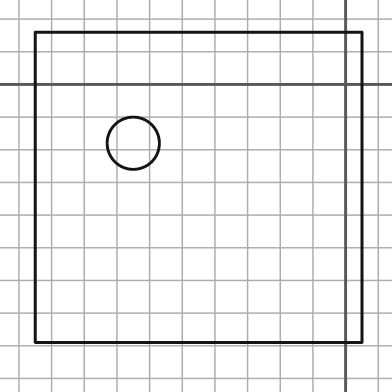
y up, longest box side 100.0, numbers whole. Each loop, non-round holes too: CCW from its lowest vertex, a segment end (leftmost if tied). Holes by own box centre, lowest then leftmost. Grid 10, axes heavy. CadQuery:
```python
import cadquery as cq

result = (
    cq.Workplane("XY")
    .moveTo(-95.0, -79.0)
    .lineTo(5.0, -79.0)
    .lineTo(5.0, 16.0)
    .lineTo(-95.0, 16.0)
    .close()
    .moveTo(-65.0, -18.0)
    .circle(8.0)
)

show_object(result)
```